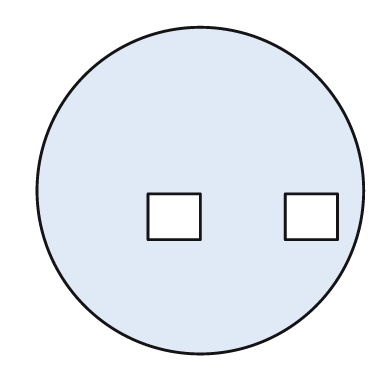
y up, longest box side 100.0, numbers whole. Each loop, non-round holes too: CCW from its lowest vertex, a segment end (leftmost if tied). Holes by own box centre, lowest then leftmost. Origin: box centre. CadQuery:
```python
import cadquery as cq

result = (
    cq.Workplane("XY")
    .moveTo(0.0, 0.0)
    .circle(50.0)
    .moveTo(-16.0, -15.0)
    .lineTo(0.0, -15.0)
    .lineTo(0.0, -1.0)
    .lineTo(-16.0, -1.0)
    .close()
    .moveTo(26.0, -15.0)
    .lineTo(42.0, -15.0)
    .lineTo(42.0, -1.0)
    .lineTo(26.0, -1.0)
    .close()
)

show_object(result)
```